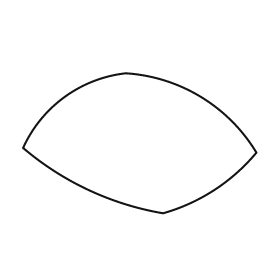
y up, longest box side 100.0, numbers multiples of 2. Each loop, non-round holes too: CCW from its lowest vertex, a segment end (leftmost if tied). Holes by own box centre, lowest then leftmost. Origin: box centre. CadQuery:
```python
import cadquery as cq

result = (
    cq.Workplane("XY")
    .moveTo(10.0, -30.0)
    .threePointArc((32.0, -20.0), (50.0, -4.0))
    .threePointArc((26.0, 20.0), (-6.0, 30.0))
    .threePointArc((-32.0, 20.0), (-50.0, -2.0))
    .threePointArc((-22.0, -20.0), (10.0, -30.0))
    .close()
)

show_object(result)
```